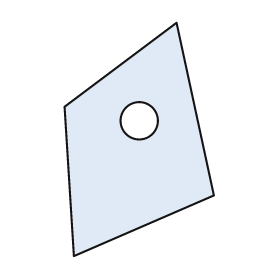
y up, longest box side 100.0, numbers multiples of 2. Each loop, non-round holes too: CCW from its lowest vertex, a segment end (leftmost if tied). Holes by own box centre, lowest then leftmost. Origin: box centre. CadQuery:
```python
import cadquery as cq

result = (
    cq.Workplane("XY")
    .moveTo(-28.0, -50.0)
    .lineTo(32.0, -24.0)
    .lineTo(16.0, 50.0)
    .lineTo(-32.0, 14.0)
    .close()
    .moveTo(0.0, 8.0)
    .circle(8.0)
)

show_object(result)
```